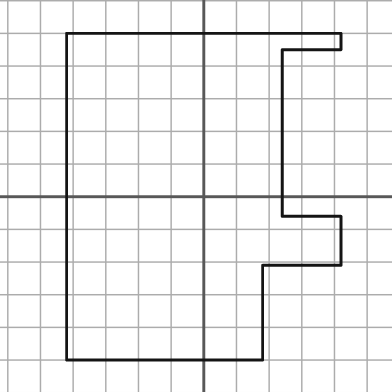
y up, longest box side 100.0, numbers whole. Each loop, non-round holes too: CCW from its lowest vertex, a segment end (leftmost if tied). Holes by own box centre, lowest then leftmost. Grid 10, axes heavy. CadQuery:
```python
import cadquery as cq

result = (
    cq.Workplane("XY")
    .moveTo(-42.0, -50.0)
    .lineTo(18.0, -50.0)
    .lineTo(18.0, -21.0)
    .lineTo(42.0, -21.0)
    .lineTo(42.0, -6.0)
    .lineTo(24.0, -6.0)
    .lineTo(24.0, 45.0)
    .lineTo(42.0, 45.0)
    .lineTo(42.0, 50.0)
    .lineTo(-42.0, 50.0)
    .close()
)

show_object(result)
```